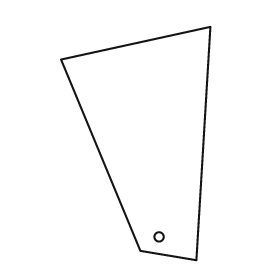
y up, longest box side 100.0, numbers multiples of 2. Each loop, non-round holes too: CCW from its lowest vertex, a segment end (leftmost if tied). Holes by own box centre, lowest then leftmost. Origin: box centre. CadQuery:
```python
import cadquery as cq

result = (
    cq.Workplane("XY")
    .moveTo(26.0, -50.0)
    .lineTo(32.0, 50.0)
    .lineTo(-32.0, 36.0)
    .lineTo(2.0, -46.0)
    .close()
    .moveTo(10.0, -40.0)
    .circle(2.0)
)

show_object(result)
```